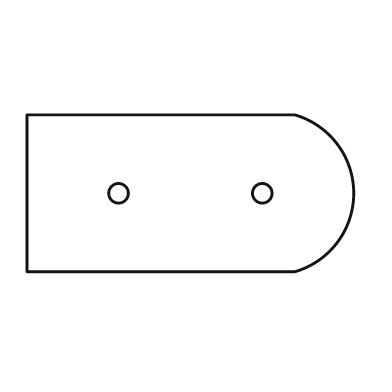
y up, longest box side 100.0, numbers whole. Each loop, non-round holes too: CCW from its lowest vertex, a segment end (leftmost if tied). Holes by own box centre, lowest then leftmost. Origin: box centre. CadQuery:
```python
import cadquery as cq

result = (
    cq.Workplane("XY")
    .moveTo(-50.0, -24.0)
    .lineTo(32.0, -24.0)
    .threePointArc((50.0, 0.0), (32.0, 24.0))
    .lineTo(-50.0, 24.0)
    .close()
    .moveTo(-22.0, 0.0)
    .circle(3.0)
    .moveTo(22.0, 0.0)
    .circle(3.0)
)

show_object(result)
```